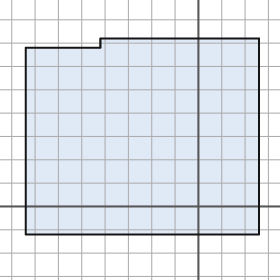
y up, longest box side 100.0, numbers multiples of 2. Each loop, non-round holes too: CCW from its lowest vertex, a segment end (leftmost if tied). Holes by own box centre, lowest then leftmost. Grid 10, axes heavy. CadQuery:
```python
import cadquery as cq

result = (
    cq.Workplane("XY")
    .moveTo(-74.0, -12.0)
    .lineTo(26.0, -12.0)
    .lineTo(26.0, 72.0)
    .lineTo(-42.0, 72.0)
    .lineTo(-42.0, 68.0)
    .lineTo(-74.0, 68.0)
    .close()
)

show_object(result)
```